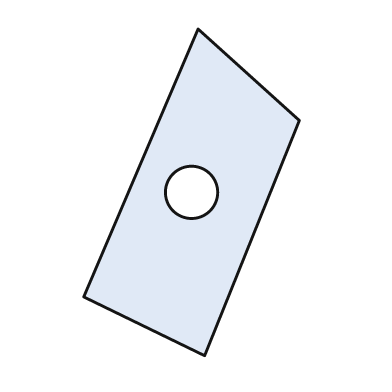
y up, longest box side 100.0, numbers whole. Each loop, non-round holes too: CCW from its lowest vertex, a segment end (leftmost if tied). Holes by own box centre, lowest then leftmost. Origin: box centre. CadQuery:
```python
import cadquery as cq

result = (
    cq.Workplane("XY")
    .moveTo(4.0, -50.0)
    .lineTo(33.0, 22.0)
    .lineTo(2.0, 50.0)
    .lineTo(-33.0, -32.0)
    .close()
    .moveTo(0.0, 0.0)
    .circle(8.0)
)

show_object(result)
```